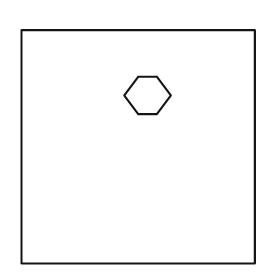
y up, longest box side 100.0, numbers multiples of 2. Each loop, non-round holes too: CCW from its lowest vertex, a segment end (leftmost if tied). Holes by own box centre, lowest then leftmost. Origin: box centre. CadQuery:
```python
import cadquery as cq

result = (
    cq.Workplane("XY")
    .moveTo(-50.0, -50.0)
    .lineTo(50.0, -50.0)
    .lineTo(50.0, 50.0)
    .lineTo(-50.0, 50.0)
    .close()
    .moveTo(0.0, 14.0)
    .lineTo(8.0, 14.0)
    .lineTo(14.0, 22.0)
    .lineTo(8.0, 30.0)
    .lineTo(0.0, 30.0)
    .lineTo(-6.0, 22.0)
    .close()
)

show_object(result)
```